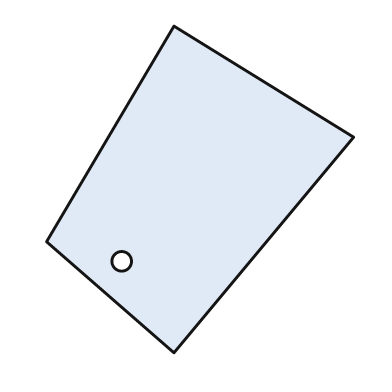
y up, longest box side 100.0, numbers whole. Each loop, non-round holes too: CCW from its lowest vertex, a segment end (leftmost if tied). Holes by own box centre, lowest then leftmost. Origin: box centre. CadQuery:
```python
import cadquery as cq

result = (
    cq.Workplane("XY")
    .moveTo(-8.0, -50.0)
    .lineTo(47.0, 16.0)
    .lineTo(-8.0, 50.0)
    .lineTo(-47.0, -16.0)
    .close()
    .moveTo(-24.0, -22.0)
    .circle(3.0)
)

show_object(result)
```